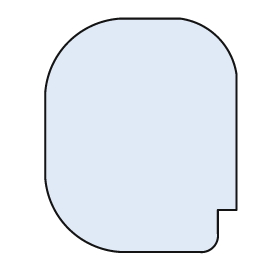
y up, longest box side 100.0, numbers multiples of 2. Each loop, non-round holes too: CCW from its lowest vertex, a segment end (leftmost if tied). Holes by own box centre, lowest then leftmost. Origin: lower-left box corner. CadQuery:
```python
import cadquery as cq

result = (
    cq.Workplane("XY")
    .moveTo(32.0, 0.0)
    .lineTo(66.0, 0.0)
    .threePointArc((72.0, 2.0), (74.0, 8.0))
    .lineTo(74.0, 18.0)
    .lineTo(82.0, 18.0)
    .lineTo(82.0, 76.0)
    .threePointArc((74.0, 92.0), (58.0, 100.0))
    .lineTo(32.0, 100.0)
    .threePointArc((10.0, 90.0), (0.0, 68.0))
    .lineTo(0.0, 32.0)
    .threePointArc((10.0, 10.0), (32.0, 0.0))
    .close()
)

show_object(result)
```